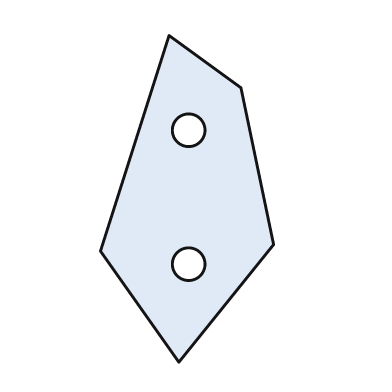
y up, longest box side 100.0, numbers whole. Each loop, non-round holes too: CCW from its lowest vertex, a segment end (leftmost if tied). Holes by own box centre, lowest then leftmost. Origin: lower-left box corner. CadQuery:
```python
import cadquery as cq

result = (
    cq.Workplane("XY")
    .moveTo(24.0, 0.0)
    .lineTo(53.0, 36.0)
    .lineTo(43.0, 84.0)
    .lineTo(21.0, 100.0)
    .lineTo(0.0, 34.0)
    .close()
    .moveTo(27.0, 30.0)
    .circle(5.0)
    .moveTo(27.0, 71.0)
    .circle(5.0)
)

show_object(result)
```